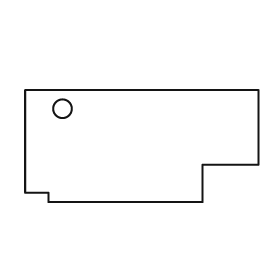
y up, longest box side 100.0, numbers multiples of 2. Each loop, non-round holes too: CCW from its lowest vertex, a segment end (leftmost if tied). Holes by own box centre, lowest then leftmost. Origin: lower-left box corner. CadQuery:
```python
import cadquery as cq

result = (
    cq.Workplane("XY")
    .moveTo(10.0, 0.0)
    .lineTo(76.0, 0.0)
    .lineTo(76.0, 16.0)
    .lineTo(100.0, 16.0)
    .lineTo(100.0, 48.0)
    .lineTo(0.0, 48.0)
    .lineTo(0.0, 4.0)
    .lineTo(10.0, 4.0)
    .close()
    .moveTo(16.0, 40.0)
    .circle(4.0)
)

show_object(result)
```